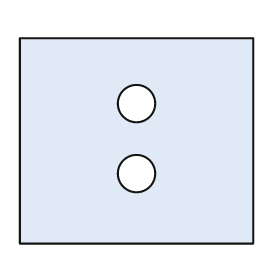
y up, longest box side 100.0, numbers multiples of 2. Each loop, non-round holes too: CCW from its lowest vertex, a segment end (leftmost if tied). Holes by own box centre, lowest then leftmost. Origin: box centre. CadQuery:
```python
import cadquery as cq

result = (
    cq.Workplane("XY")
    .moveTo(-50.0, -44.0)
    .lineTo(50.0, -44.0)
    .lineTo(50.0, 44.0)
    .lineTo(-50.0, 44.0)
    .close()
    .moveTo(0.0, -14.0)
    .circle(8.0)
    .moveTo(0.0, 16.0)
    .circle(8.0)
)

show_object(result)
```